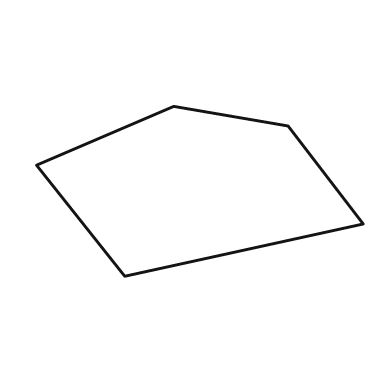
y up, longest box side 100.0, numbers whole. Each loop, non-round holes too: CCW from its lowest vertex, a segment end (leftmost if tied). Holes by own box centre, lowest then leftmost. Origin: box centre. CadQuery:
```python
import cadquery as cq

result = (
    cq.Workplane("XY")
    .moveTo(-23.0, -26.0)
    .lineTo(50.0, -10.0)
    .lineTo(27.0, 20.0)
    .lineTo(-8.0, 26.0)
    .lineTo(-50.0, 8.0)
    .close()
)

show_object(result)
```